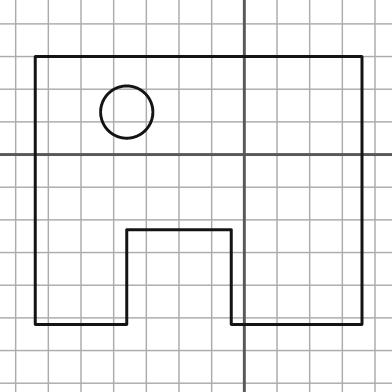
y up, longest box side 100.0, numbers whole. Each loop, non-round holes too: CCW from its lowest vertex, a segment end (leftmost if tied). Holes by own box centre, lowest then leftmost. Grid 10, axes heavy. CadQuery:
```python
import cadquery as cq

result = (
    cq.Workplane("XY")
    .moveTo(-64.0, -52.0)
    .lineTo(-36.0, -52.0)
    .lineTo(-36.0, -23.0)
    .lineTo(-4.0, -23.0)
    .lineTo(-4.0, -52.0)
    .lineTo(36.0, -52.0)
    .lineTo(36.0, 30.0)
    .lineTo(-64.0, 30.0)
    .close()
    .moveTo(-36.0, 13.0)
    .circle(8.0)
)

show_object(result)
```